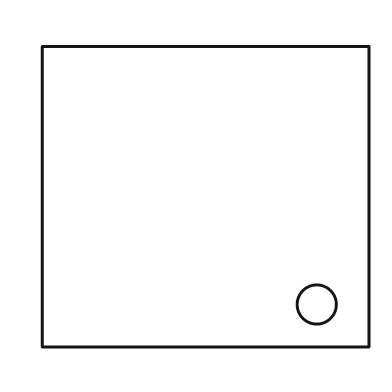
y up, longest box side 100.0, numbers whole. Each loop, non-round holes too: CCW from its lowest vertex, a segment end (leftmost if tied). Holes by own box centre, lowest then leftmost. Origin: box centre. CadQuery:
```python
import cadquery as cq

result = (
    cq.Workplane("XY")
    .moveTo(-50.0, -46.0)
    .lineTo(50.0, -46.0)
    .lineTo(50.0, 46.0)
    .lineTo(-50.0, 46.0)
    .close()
    .moveTo(34.0, -33.0)
    .circle(6.0)
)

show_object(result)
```